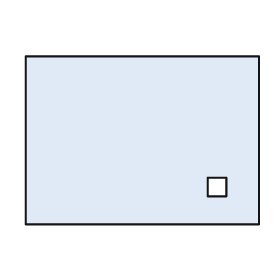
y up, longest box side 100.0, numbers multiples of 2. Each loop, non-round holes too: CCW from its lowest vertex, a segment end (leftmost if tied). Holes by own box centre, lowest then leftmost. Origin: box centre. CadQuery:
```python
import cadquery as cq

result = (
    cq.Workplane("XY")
    .moveTo(-50.0, -36.0)
    .lineTo(50.0, -36.0)
    .lineTo(50.0, 36.0)
    .lineTo(-50.0, 36.0)
    .close()
    .moveTo(28.0, -24.0)
    .lineTo(36.0, -24.0)
    .lineTo(36.0, -16.0)
    .lineTo(28.0, -16.0)
    .close()
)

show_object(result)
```